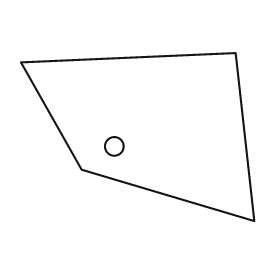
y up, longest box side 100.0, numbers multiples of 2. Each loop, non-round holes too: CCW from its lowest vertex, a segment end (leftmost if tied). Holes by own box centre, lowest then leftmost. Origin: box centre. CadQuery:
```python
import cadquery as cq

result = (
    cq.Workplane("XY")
    .moveTo(50.0, -36.0)
    .lineTo(42.0, 36.0)
    .lineTo(-50.0, 32.0)
    .lineTo(-24.0, -14.0)
    .close()
    .moveTo(-10.0, -4.0)
    .circle(4.0)
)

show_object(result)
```